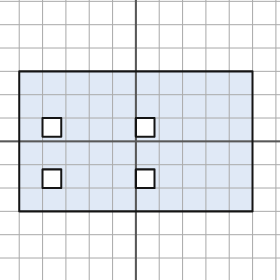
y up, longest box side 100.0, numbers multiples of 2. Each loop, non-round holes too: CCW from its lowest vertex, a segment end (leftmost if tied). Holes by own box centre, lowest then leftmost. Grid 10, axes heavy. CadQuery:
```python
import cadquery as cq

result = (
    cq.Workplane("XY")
    .moveTo(-50.0, -30.0)
    .lineTo(50.0, -30.0)
    .lineTo(50.0, 30.0)
    .lineTo(-50.0, 30.0)
    .close()
    .moveTo(-40.0, -20.0)
    .lineTo(-32.0, -20.0)
    .lineTo(-32.0, -12.0)
    .lineTo(-40.0, -12.0)
    .close()
    .moveTo(0.0, -20.0)
    .lineTo(8.0, -20.0)
    .lineTo(8.0, -12.0)
    .lineTo(0.0, -12.0)
    .close()
    .moveTo(-40.0, 2.0)
    .lineTo(-32.0, 2.0)
    .lineTo(-32.0, 10.0)
    .lineTo(-40.0, 10.0)
    .close()
    .moveTo(0.0, 2.0)
    .lineTo(8.0, 2.0)
    .lineTo(8.0, 10.0)
    .lineTo(0.0, 10.0)
    .close()
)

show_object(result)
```